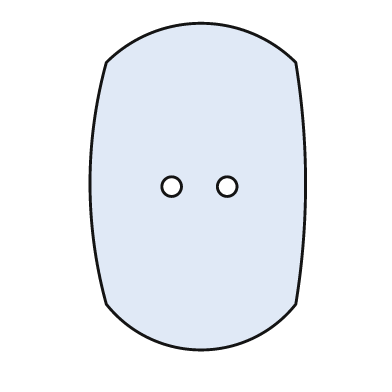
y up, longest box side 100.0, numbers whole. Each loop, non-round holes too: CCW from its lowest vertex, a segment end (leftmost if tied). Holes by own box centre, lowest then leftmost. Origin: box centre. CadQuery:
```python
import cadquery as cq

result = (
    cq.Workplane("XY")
    .moveTo(-28.0, -36.0)
    .threePointArc((1.0, -50.0), (30.0, -36.0))
    .threePointArc((33.0, 1.0), (30.0, 38.0))
    .threePointArc((1.0, 50.0), (-28.0, 38.0))
    .threePointArc((-33.0, 1.0), (-28.0, -36.0))
    .close()
    .moveTo(-8.0, 0.0)
    .circle(3.0)
    .moveTo(9.0, 0.0)
    .circle(3.0)
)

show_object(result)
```